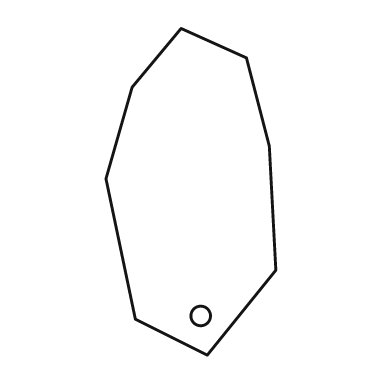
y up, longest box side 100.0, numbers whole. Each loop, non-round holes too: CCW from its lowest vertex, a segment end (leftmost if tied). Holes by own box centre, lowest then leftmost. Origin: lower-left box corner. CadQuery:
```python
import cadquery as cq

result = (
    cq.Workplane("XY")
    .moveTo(31.0, 0.0)
    .lineTo(52.0, 26.0)
    .lineTo(50.0, 64.0)
    .lineTo(43.0, 91.0)
    .lineTo(23.0, 100.0)
    .lineTo(8.0, 82.0)
    .lineTo(0.0, 54.0)
    .lineTo(9.0, 11.0)
    .close()
    .moveTo(29.0, 12.0)
    .circle(3.0)
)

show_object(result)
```